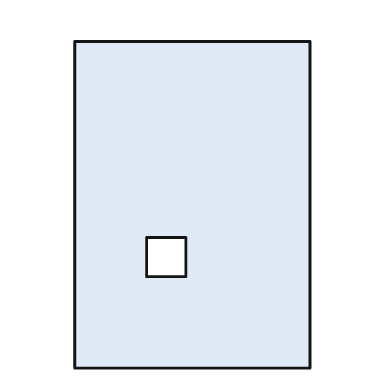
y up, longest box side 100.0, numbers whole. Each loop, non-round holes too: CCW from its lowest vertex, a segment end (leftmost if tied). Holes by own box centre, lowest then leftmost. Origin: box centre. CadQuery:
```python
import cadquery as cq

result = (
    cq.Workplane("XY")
    .moveTo(-36.0, -50.0)
    .lineTo(36.0, -50.0)
    .lineTo(36.0, 50.0)
    .lineTo(-36.0, 50.0)
    .close()
    .moveTo(-14.0, -22.0)
    .lineTo(-2.0, -22.0)
    .lineTo(-2.0, -10.0)
    .lineTo(-14.0, -10.0)
    .close()
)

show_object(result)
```